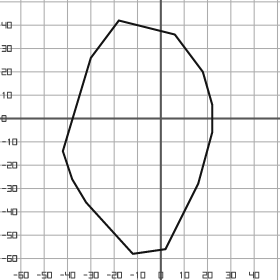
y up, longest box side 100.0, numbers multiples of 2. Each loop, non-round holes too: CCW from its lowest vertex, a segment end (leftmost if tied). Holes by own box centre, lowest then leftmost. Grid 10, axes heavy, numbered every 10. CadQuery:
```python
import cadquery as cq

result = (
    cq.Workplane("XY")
    .moveTo(-12.0, -58.0)
    .lineTo(2.0, -56.0)
    .lineTo(16.0, -28.0)
    .lineTo(22.0, -6.0)
    .lineTo(22.0, 6.0)
    .lineTo(18.0, 20.0)
    .lineTo(6.0, 36.0)
    .lineTo(-18.0, 42.0)
    .lineTo(-30.0, 26.0)
    .lineTo(-42.0, -14.0)
    .lineTo(-38.0, -26.0)
    .lineTo(-32.0, -36.0)
    .close()
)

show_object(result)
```